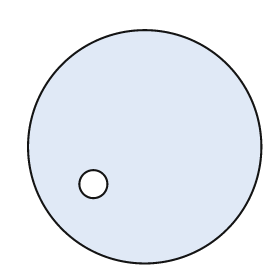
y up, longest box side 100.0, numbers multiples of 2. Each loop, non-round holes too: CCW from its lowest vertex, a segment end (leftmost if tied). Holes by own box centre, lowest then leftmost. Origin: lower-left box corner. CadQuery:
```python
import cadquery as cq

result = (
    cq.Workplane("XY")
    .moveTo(50.0, 50.0)
    .circle(50.0)
    .moveTo(28.0, 34.0)
    .circle(6.0)
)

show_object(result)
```